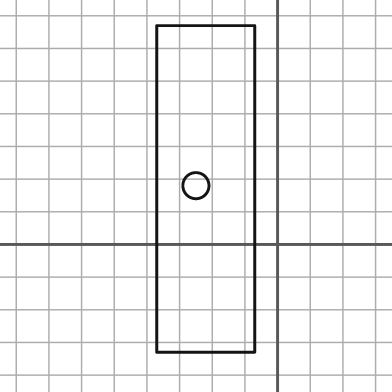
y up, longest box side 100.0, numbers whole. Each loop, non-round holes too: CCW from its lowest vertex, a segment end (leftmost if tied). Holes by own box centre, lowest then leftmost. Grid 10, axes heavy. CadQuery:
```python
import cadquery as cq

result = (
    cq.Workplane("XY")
    .moveTo(-37.0, -33.0)
    .lineTo(-7.0, -33.0)
    .lineTo(-7.0, 67.0)
    .lineTo(-37.0, 67.0)
    .close()
    .moveTo(-25.0, 18.0)
    .circle(4.0)
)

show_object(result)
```